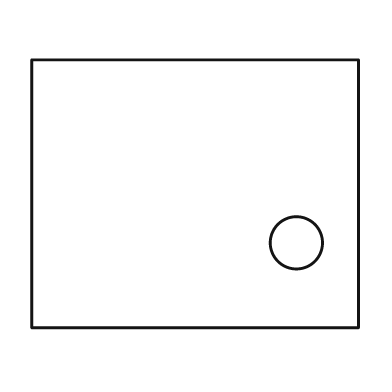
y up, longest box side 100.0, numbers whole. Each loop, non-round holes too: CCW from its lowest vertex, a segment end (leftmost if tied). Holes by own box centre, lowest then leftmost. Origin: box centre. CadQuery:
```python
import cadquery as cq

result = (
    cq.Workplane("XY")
    .moveTo(-50.0, -41.0)
    .lineTo(50.0, -41.0)
    .lineTo(50.0, 41.0)
    .lineTo(-50.0, 41.0)
    .close()
    .moveTo(31.0, -15.0)
    .circle(8.0)
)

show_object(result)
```